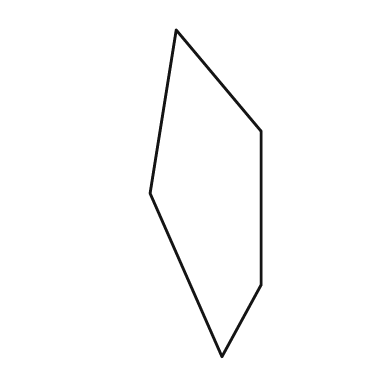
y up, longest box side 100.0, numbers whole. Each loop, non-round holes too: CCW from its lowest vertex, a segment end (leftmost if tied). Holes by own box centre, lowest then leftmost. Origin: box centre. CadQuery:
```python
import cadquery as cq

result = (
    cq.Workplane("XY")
    .moveTo(5.0, -50.0)
    .lineTo(17.0, -28.0)
    .lineTo(17.0, 19.0)
    .lineTo(-9.0, 50.0)
    .lineTo(-17.0, 0.0)
    .close()
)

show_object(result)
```